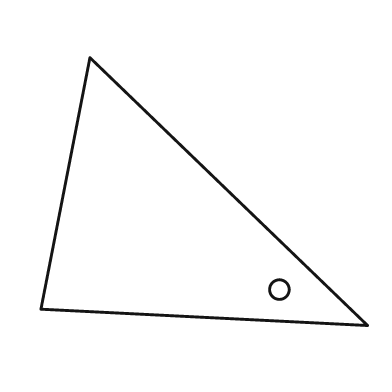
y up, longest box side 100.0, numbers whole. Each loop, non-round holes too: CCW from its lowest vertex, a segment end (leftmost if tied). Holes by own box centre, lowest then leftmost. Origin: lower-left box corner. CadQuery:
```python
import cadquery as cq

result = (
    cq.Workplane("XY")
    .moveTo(100.0, 0.0)
    .lineTo(15.0, 82.0)
    .lineTo(0.0, 5.0)
    .close()
    .moveTo(73.0, 11.0)
    .circle(3.0)
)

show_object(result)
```